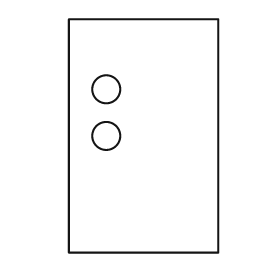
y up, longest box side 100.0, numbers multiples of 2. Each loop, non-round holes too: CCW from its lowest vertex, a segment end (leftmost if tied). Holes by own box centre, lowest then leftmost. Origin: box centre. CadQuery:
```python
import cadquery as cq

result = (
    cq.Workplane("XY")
    .moveTo(-32.0, -50.0)
    .lineTo(32.0, -50.0)
    .lineTo(32.0, 50.0)
    .lineTo(-32.0, 50.0)
    .close()
    .moveTo(-16.0, 0.0)
    .circle(6.0)
    .moveTo(-16.0, 20.0)
    .circle(6.0)
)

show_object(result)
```